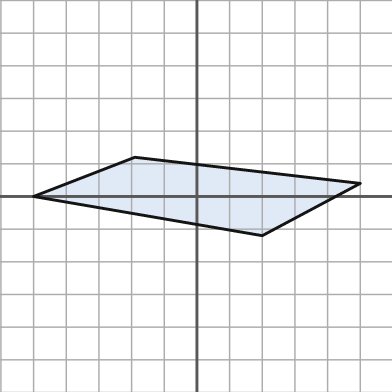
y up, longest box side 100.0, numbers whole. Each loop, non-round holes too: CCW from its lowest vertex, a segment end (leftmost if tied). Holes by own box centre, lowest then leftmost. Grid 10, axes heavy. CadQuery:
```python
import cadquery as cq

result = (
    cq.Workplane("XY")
    .moveTo(20.0, -12.0)
    .lineTo(50.0, 4.0)
    .lineTo(-19.0, 12.0)
    .lineTo(-50.0, 0.0)
    .close()
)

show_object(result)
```